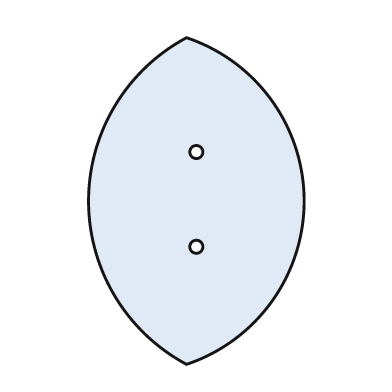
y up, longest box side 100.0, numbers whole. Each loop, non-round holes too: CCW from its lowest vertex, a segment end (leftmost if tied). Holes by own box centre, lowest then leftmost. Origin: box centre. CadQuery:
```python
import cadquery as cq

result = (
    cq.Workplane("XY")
    .moveTo(-3.0, -50.0)
    .threePointArc((33.0, 0.0), (-3.0, 50.0))
    .threePointArc((-33.0, 0.0), (-3.0, -50.0))
    .close()
    .moveTo(0.0, -14.0)
    .circle(2.0)
    .moveTo(0.0, 15.0)
    .circle(2.0)
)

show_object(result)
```